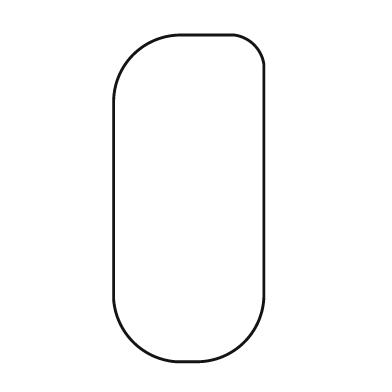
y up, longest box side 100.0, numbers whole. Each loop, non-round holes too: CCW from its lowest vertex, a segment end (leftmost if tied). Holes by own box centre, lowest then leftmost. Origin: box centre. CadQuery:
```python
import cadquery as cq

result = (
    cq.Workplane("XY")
    .moveTo(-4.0, -50.0)
    .lineTo(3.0, -50.0)
    .threePointArc((17.0, -44.0), (23.0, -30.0))
    .lineTo(23.0, 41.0)
    .threePointArc((20.0, 47.0), (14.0, 50.0))
    .lineTo(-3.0, 50.0)
    .threePointArc((-17.0, 44.0), (-23.0, 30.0))
    .lineTo(-23.0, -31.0)
    .threePointArc((-17.0, -44.0), (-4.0, -50.0))
    .close()
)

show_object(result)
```